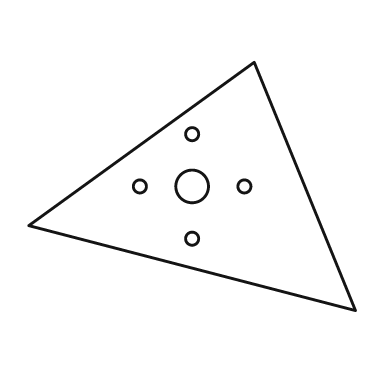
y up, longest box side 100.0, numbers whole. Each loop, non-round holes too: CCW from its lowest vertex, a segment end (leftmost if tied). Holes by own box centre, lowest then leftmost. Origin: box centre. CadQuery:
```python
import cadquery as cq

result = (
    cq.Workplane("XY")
    .moveTo(50.0, -38.0)
    .lineTo(19.0, 38.0)
    .lineTo(-50.0, -12.0)
    .close()
    .moveTo(0.0, -16.0)
    .circle(2.0)
    .moveTo(-16.0, 0.0)
    .circle(2.0)
    .moveTo(0.0, 0.0)
    .circle(5.0)
    .moveTo(16.0, 0.0)
    .circle(2.0)
    .moveTo(0.0, 16.0)
    .circle(2.0)
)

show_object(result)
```